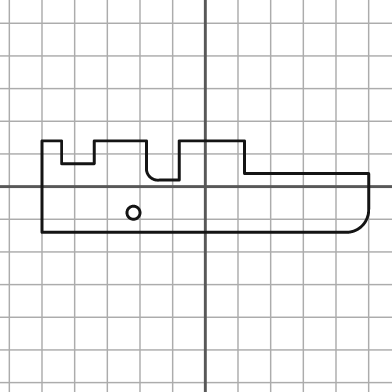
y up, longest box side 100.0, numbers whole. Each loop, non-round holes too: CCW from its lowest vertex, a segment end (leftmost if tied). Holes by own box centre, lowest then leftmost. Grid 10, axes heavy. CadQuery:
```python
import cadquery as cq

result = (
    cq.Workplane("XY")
    .moveTo(-50.0, -14.0)
    .lineTo(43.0, -14.0)
    .threePointArc((48.0, -12.0), (50.0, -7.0))
    .lineTo(50.0, 4.0)
    .lineTo(12.0, 4.0)
    .lineTo(12.0, 14.0)
    .lineTo(-8.0, 14.0)
    .lineTo(-8.0, 2.0)
    .lineTo(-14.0, 2.0)
    .threePointArc((-17.0, 3.0), (-18.0, 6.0))
    .lineTo(-18.0, 14.0)
    .lineTo(-34.0, 14.0)
    .lineTo(-34.0, 7.0)
    .lineTo(-44.0, 7.0)
    .lineTo(-44.0, 14.0)
    .lineTo(-50.0, 14.0)
    .close()
    .moveTo(-22.0, -8.0)
    .circle(2.0)
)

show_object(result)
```